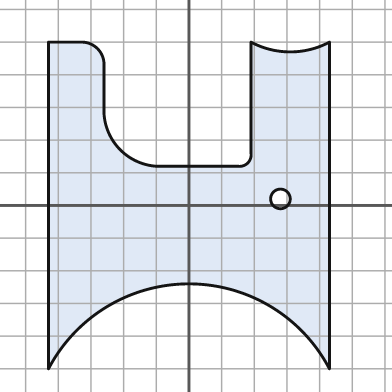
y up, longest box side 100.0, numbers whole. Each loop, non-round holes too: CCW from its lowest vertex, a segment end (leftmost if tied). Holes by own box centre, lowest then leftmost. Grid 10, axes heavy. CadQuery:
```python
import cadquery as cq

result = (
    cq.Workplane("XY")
    .moveTo(-43.0, -50.0)
    .threePointArc((0.0, -24.0), (43.0, -50.0))
    .lineTo(43.0, 50.0)
    .threePointArc((31.0, 47.0), (19.0, 50.0))
    .lineTo(19.0, 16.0)
    .threePointArc((18.0, 13.0), (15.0, 12.0))
    .lineTo(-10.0, 12.0)
    .threePointArc((-21.0, 17.0), (-26.0, 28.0))
    .lineTo(-26.0, 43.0)
    .threePointArc((-28.0, 48.0), (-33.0, 50.0))
    .lineTo(-43.0, 50.0)
    .close()
    .moveTo(28.0, 2.0)
    .circle(3.0)
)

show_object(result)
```